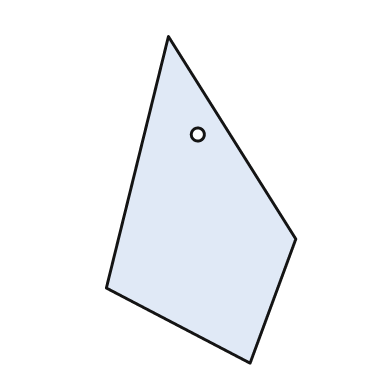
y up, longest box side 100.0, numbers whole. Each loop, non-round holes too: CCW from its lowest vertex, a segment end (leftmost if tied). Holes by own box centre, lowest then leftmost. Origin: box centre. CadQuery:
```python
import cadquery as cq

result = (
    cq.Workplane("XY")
    .moveTo(15.0, -50.0)
    .lineTo(29.0, -12.0)
    .lineTo(-10.0, 50.0)
    .lineTo(-29.0, -27.0)
    .close()
    .moveTo(-1.0, 20.0)
    .circle(2.0)
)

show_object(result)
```